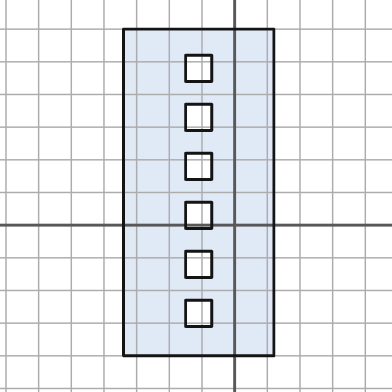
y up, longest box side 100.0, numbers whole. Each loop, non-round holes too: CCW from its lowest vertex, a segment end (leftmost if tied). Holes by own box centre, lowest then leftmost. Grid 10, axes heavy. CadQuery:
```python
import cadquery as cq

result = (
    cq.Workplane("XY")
    .moveTo(-34.0, -40.0)
    .lineTo(12.0, -40.0)
    .lineTo(12.0, 60.0)
    .lineTo(-34.0, 60.0)
    .close()
    .moveTo(-15.0, -31.0)
    .lineTo(-7.0, -31.0)
    .lineTo(-7.0, -23.0)
    .lineTo(-15.0, -23.0)
    .close()
    .moveTo(-15.0, -16.0)
    .lineTo(-7.0, -16.0)
    .lineTo(-7.0, -8.0)
    .lineTo(-15.0, -8.0)
    .close()
    .moveTo(-15.0, -1.0)
    .lineTo(-7.0, -1.0)
    .lineTo(-7.0, 7.0)
    .lineTo(-15.0, 7.0)
    .close()
    .moveTo(-15.0, 14.0)
    .lineTo(-7.0, 14.0)
    .lineTo(-7.0, 22.0)
    .lineTo(-15.0, 22.0)
    .close()
    .moveTo(-15.0, 29.0)
    .lineTo(-7.0, 29.0)
    .lineTo(-7.0, 37.0)
    .lineTo(-15.0, 37.0)
    .close()
    .moveTo(-15.0, 44.0)
    .lineTo(-7.0, 44.0)
    .lineTo(-7.0, 52.0)
    .lineTo(-15.0, 52.0)
    .close()
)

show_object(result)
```